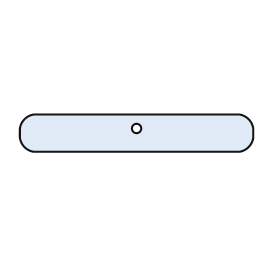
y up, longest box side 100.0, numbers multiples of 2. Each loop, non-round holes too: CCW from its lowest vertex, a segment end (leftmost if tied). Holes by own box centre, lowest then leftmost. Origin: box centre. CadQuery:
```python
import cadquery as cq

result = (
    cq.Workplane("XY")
    .moveTo(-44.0, -8.0)
    .lineTo(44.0, -8.0)
    .threePointArc((48.0, -6.0), (50.0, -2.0))
    .lineTo(50.0, 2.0)
    .threePointArc((48.0, 6.0), (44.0, 8.0))
    .lineTo(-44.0, 8.0)
    .threePointArc((-48.0, 6.0), (-50.0, 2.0))
    .lineTo(-50.0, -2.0)
    .threePointArc((-48.0, -6.0), (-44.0, -8.0))
    .close()
    .moveTo(0.0, 2.0)
    .circle(2.0)
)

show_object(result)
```